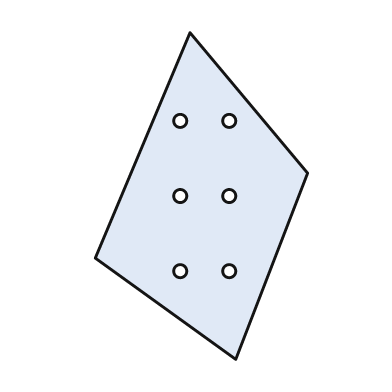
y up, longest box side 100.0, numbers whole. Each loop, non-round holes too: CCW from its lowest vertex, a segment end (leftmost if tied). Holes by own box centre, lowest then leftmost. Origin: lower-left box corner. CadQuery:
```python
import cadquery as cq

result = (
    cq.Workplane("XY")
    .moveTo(43.0, 0.0)
    .lineTo(65.0, 57.0)
    .lineTo(29.0, 100.0)
    .lineTo(0.0, 31.0)
    .close()
    .moveTo(26.0, 27.0)
    .circle(2.0)
    .moveTo(41.0, 27.0)
    .circle(2.0)
    .moveTo(26.0, 50.0)
    .circle(2.0)
    .moveTo(41.0, 50.0)
    .circle(2.0)
    .moveTo(26.0, 73.0)
    .circle(2.0)
    .moveTo(41.0, 73.0)
    .circle(2.0)
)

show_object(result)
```